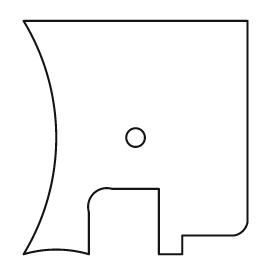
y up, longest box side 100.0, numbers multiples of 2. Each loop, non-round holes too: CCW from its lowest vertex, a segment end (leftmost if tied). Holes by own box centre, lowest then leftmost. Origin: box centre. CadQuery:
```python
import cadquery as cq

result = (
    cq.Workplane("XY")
    .moveTo(-48.0, -50.0)
    .threePointArc((-34.0, -48.0), (-20.0, -50.0))
    .lineTo(-20.0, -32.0)
    .threePointArc((-18.0, -24.0), (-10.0, -22.0))
    .lineTo(10.0, -22.0)
    .lineTo(10.0, -50.0)
    .lineTo(20.0, -50.0)
    .lineTo(20.0, -42.0)
    .lineTo(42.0, -42.0)
    .threePointArc((46.0, -40.0), (48.0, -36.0))
    .lineTo(48.0, 50.0)
    .lineTo(-48.0, 50.0)
    .threePointArc((-34.0, 0.0), (-48.0, -50.0))
    .close()
    .moveTo(0.0, 0.0)
    .circle(4.0)
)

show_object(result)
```